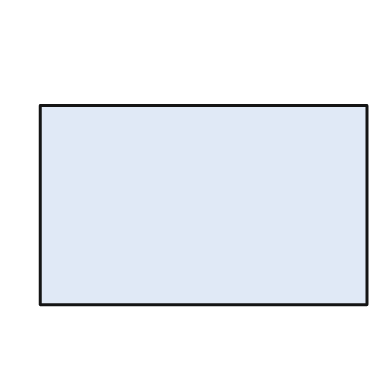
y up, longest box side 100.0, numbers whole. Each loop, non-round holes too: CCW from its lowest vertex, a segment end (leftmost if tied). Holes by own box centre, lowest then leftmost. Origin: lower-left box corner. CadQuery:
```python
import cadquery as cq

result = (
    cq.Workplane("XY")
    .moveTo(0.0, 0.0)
    .lineTo(100.0, 0.0)
    .lineTo(100.0, 61.0)
    .lineTo(0.0, 61.0)
    .close()
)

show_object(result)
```